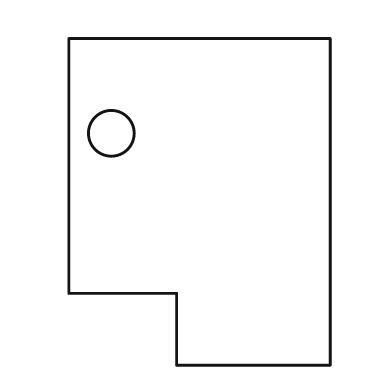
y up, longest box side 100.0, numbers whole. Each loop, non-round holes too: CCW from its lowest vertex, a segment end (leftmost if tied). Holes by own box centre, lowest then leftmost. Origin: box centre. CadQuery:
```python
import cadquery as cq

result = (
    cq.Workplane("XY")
    .moveTo(-7.0, -50.0)
    .lineTo(40.0, -50.0)
    .lineTo(40.0, 50.0)
    .lineTo(-40.0, 50.0)
    .lineTo(-40.0, -28.0)
    .lineTo(-7.0, -28.0)
    .close()
    .moveTo(-27.0, 21.0)
    .circle(7.0)
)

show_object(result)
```